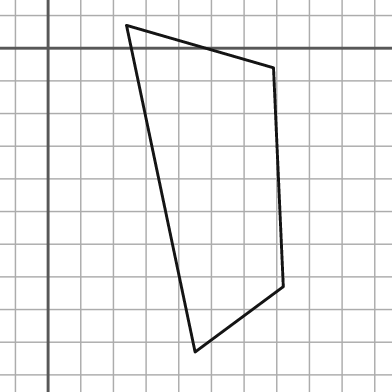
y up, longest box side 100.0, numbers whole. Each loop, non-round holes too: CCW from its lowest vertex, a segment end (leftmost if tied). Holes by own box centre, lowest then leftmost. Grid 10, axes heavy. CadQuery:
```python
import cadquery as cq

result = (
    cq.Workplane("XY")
    .moveTo(45.0, -93.0)
    .lineTo(72.0, -73.0)
    .lineTo(69.0, -6.0)
    .lineTo(24.0, 7.0)
    .close()
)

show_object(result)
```